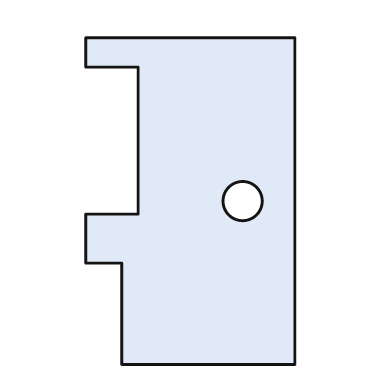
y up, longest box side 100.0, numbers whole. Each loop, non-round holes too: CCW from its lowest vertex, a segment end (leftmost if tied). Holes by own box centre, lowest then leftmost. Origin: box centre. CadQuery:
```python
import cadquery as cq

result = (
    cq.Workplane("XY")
    .moveTo(-21.0, -50.0)
    .lineTo(32.0, -50.0)
    .lineTo(32.0, 50.0)
    .lineTo(-32.0, 50.0)
    .lineTo(-32.0, 41.0)
    .lineTo(-16.0, 41.0)
    .lineTo(-16.0, -4.0)
    .lineTo(-32.0, -4.0)
    .lineTo(-32.0, -19.0)
    .lineTo(-21.0, -19.0)
    .close()
    .moveTo(16.0, 0.0)
    .circle(6.0)
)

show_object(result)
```